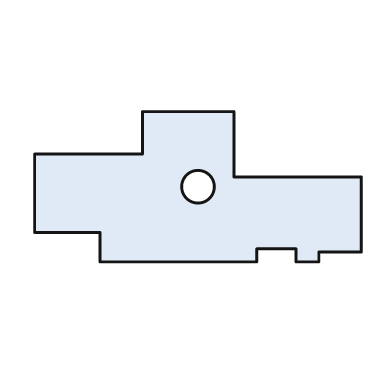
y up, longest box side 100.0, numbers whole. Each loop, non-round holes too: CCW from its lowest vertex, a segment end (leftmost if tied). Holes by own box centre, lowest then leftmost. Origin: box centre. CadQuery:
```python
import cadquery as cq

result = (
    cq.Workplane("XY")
    .moveTo(-30.0, -23.0)
    .lineTo(18.0, -23.0)
    .lineTo(18.0, -19.0)
    .lineTo(30.0, -19.0)
    .lineTo(30.0, -23.0)
    .lineTo(37.0, -23.0)
    .lineTo(37.0, -20.0)
    .lineTo(50.0, -20.0)
    .lineTo(50.0, 3.0)
    .lineTo(11.0, 3.0)
    .lineTo(11.0, 23.0)
    .lineTo(-17.0, 23.0)
    .lineTo(-17.0, 10.0)
    .lineTo(-50.0, 10.0)
    .lineTo(-50.0, -14.0)
    .lineTo(-30.0, -14.0)
    .close()
    .moveTo(0.0, 0.0)
    .circle(5.0)
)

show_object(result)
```